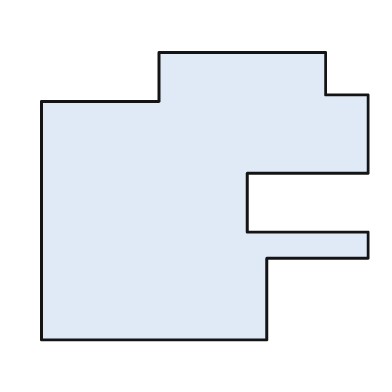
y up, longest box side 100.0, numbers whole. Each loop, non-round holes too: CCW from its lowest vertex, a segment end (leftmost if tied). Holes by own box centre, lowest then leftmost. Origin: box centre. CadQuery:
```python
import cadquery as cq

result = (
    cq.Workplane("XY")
    .moveTo(-50.0, -44.0)
    .lineTo(19.0, -44.0)
    .lineTo(19.0, -19.0)
    .lineTo(50.0, -19.0)
    .lineTo(50.0, -11.0)
    .lineTo(13.0, -11.0)
    .lineTo(13.0, 7.0)
    .lineTo(50.0, 7.0)
    .lineTo(50.0, 31.0)
    .lineTo(37.0, 31.0)
    .lineTo(37.0, 44.0)
    .lineTo(-14.0, 44.0)
    .lineTo(-14.0, 29.0)
    .lineTo(-50.0, 29.0)
    .close()
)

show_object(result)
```